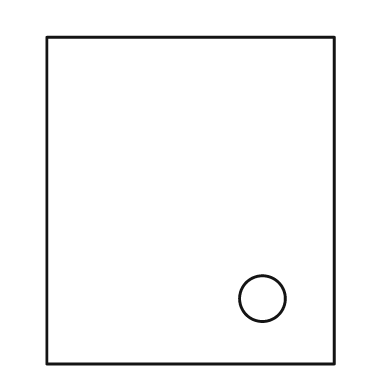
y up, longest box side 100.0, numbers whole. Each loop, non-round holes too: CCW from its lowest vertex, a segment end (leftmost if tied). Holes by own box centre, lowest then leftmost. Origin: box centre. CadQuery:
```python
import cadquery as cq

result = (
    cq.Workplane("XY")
    .moveTo(-44.0, -50.0)
    .lineTo(44.0, -50.0)
    .lineTo(44.0, 50.0)
    .lineTo(-44.0, 50.0)
    .close()
    .moveTo(22.0, -30.0)
    .circle(7.0)
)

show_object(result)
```